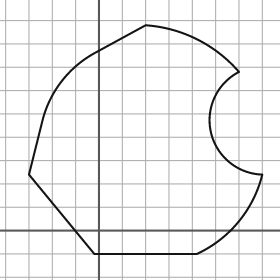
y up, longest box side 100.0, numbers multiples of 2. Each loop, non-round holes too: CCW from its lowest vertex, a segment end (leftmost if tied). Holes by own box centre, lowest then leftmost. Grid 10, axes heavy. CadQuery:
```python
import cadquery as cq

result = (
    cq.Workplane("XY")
    .moveTo(-2.0, -10.0)
    .lineTo(42.0, -10.0)
    .threePointArc((60.0, 4.0), (70.0, 24.0))
    .threePointArc((48.0, 42.0), (60.0, 68.0))
    .threePointArc((42.0, 82.0), (20.0, 88.0))
    .lineTo(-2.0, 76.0)
    .threePointArc((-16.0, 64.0), (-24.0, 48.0))
    .lineTo(-30.0, 24.0)
    .close()
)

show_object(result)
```